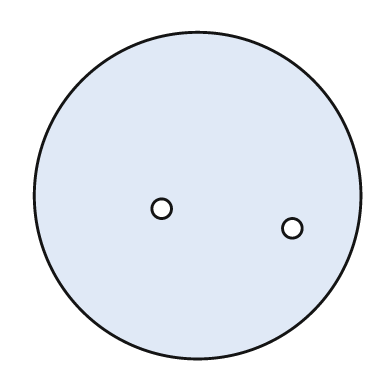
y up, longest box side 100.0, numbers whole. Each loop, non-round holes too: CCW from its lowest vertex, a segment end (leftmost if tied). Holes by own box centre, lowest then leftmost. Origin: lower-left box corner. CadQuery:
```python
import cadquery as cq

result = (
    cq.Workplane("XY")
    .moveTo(50.0, 50.0)
    .circle(50.0)
    .moveTo(79.0, 40.0)
    .circle(3.0)
    .moveTo(39.0, 46.0)
    .circle(3.0)
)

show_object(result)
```